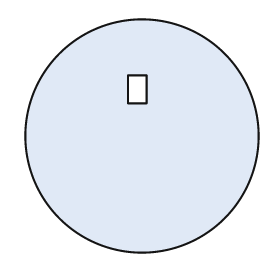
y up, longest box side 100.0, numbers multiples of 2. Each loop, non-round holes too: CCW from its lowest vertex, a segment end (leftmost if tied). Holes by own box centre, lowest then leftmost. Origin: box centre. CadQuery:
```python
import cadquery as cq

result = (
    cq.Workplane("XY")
    .moveTo(0.0, 0.0)
    .circle(50.0)
    .moveTo(-6.0, 14.0)
    .lineTo(2.0, 14.0)
    .lineTo(2.0, 26.0)
    .lineTo(-6.0, 26.0)
    .close()
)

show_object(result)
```